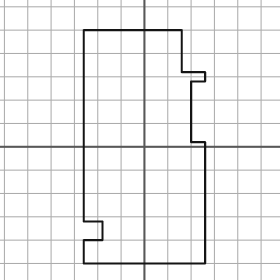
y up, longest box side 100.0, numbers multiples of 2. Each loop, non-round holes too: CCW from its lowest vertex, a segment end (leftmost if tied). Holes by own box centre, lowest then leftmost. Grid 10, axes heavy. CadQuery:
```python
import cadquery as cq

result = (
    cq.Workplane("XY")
    .moveTo(-26.0, -50.0)
    .lineTo(26.0, -50.0)
    .lineTo(26.0, 2.0)
    .lineTo(20.0, 2.0)
    .lineTo(20.0, 28.0)
    .lineTo(26.0, 28.0)
    .lineTo(26.0, 32.0)
    .lineTo(16.0, 32.0)
    .lineTo(16.0, 50.0)
    .lineTo(-26.0, 50.0)
    .lineTo(-26.0, -32.0)
    .lineTo(-18.0, -32.0)
    .lineTo(-18.0, -40.0)
    .lineTo(-26.0, -40.0)
    .close()
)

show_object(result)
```